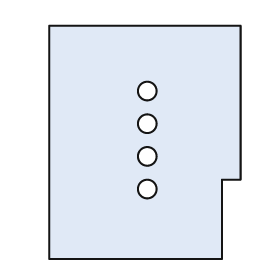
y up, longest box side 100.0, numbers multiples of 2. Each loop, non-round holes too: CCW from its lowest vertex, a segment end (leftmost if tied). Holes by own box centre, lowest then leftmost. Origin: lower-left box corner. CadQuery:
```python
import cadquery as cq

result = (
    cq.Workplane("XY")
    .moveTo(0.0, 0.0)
    .lineTo(74.0, 0.0)
    .lineTo(74.0, 34.0)
    .lineTo(82.0, 34.0)
    .lineTo(82.0, 100.0)
    .lineTo(0.0, 100.0)
    .close()
    .moveTo(42.0, 30.0)
    .circle(4.0)
    .moveTo(42.0, 44.0)
    .circle(4.0)
    .moveTo(42.0, 58.0)
    .circle(4.0)
    .moveTo(42.0, 72.0)
    .circle(4.0)
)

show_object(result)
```